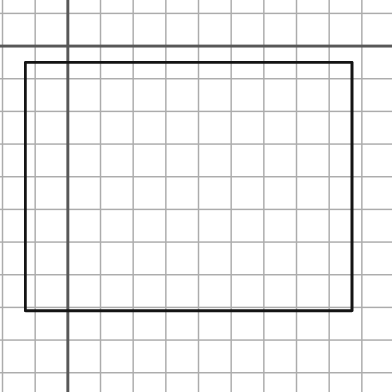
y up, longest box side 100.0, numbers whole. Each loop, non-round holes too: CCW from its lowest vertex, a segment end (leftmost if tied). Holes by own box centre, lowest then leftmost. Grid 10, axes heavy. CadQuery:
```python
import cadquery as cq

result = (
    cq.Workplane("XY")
    .moveTo(-13.0, -81.0)
    .lineTo(87.0, -81.0)
    .lineTo(87.0, -5.0)
    .lineTo(-13.0, -5.0)
    .close()
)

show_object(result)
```